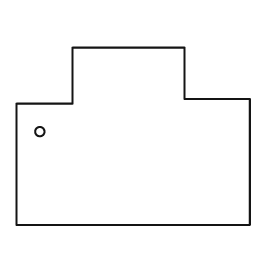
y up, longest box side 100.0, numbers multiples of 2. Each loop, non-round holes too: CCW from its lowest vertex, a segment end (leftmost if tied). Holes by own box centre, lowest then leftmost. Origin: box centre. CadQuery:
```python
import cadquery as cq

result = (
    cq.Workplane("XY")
    .moveTo(-50.0, -38.0)
    .lineTo(50.0, -38.0)
    .lineTo(50.0, 16.0)
    .lineTo(22.0, 16.0)
    .lineTo(22.0, 38.0)
    .lineTo(-26.0, 38.0)
    .lineTo(-26.0, 14.0)
    .lineTo(-50.0, 14.0)
    .close()
    .moveTo(-40.0, 2.0)
    .circle(2.0)
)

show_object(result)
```